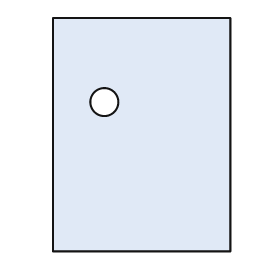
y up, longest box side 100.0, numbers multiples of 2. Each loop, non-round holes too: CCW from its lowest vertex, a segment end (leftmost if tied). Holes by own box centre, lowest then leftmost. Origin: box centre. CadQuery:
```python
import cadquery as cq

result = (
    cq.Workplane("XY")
    .moveTo(-38.0, -50.0)
    .lineTo(38.0, -50.0)
    .lineTo(38.0, 50.0)
    .lineTo(-38.0, 50.0)
    .close()
    .moveTo(-16.0, 14.0)
    .circle(6.0)
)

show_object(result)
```